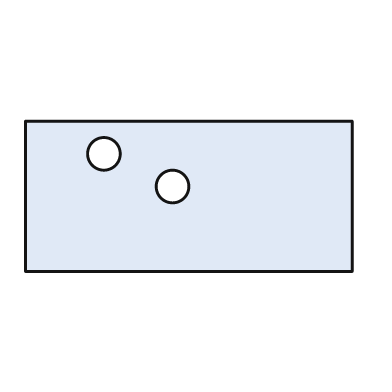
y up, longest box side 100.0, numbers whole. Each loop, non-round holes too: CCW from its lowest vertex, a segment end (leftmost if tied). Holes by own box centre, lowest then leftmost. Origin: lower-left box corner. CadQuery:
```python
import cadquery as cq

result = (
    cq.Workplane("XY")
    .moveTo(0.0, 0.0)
    .lineTo(100.0, 0.0)
    .lineTo(100.0, 46.0)
    .lineTo(0.0, 46.0)
    .close()
    .moveTo(45.0, 26.0)
    .circle(5.0)
    .moveTo(24.0, 36.0)
    .circle(5.0)
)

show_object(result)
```